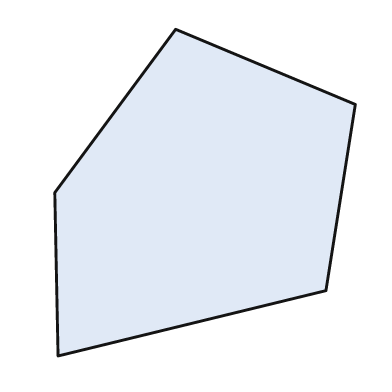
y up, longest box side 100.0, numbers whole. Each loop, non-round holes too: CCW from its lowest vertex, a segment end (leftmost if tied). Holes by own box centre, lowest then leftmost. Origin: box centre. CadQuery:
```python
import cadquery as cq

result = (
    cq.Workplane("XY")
    .moveTo(-45.0, -50.0)
    .lineTo(37.0, -30.0)
    .lineTo(46.0, 27.0)
    .lineTo(-9.0, 50.0)
    .lineTo(-46.0, 0.0)
    .close()
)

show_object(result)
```